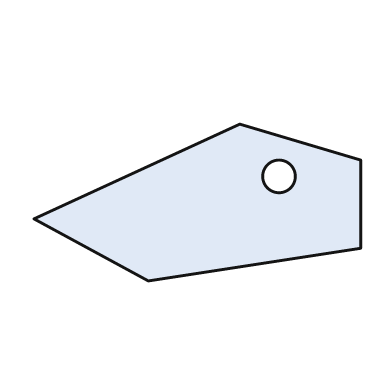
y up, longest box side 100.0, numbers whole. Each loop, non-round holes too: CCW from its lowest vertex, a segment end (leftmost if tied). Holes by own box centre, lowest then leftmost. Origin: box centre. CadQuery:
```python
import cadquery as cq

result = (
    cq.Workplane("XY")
    .moveTo(-15.0, -24.0)
    .lineTo(50.0, -14.0)
    .lineTo(50.0, 13.0)
    .lineTo(13.0, 24.0)
    .lineTo(-50.0, -5.0)
    .close()
    .moveTo(25.0, 8.0)
    .circle(5.0)
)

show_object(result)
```